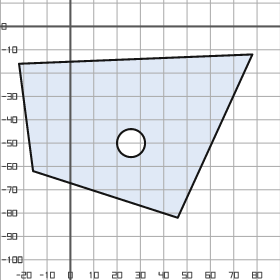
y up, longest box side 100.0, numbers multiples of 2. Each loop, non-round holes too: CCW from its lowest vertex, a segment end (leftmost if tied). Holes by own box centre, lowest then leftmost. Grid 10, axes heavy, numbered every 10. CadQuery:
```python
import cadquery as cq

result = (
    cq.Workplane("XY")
    .moveTo(46.0, -82.0)
    .lineTo(78.0, -12.0)
    .lineTo(-22.0, -16.0)
    .lineTo(-16.0, -62.0)
    .close()
    .moveTo(26.0, -50.0)
    .circle(6.0)
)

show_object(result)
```